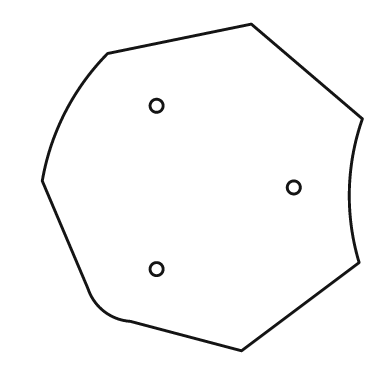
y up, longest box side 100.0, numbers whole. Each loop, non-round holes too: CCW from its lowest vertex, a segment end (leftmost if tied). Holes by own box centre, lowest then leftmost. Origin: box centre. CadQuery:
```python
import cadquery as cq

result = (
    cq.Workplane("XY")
    .moveTo(12.0, -50.0)
    .lineTo(48.0, -23.0)
    .threePointArc((45.0, -1.0), (49.0, 21.0))
    .lineTo(15.0, 50.0)
    .lineTo(-29.0, 41.0)
    .threePointArc((-42.0, 23.0), (-49.0, 2.0))
    .lineTo(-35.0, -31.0)
    .threePointArc((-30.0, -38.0), (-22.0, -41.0))
    .close()
    .moveTo(-14.0, -25.0)
    .circle(2.0)
    .moveTo(28.0, 0.0)
    .circle(2.0)
    .moveTo(-14.0, 25.0)
    .circle(2.0)
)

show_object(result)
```